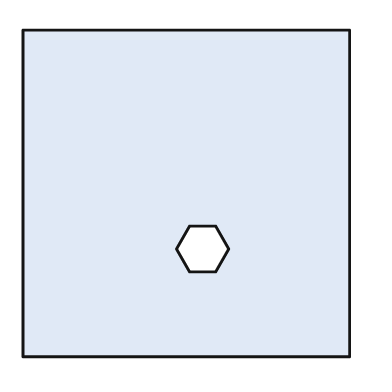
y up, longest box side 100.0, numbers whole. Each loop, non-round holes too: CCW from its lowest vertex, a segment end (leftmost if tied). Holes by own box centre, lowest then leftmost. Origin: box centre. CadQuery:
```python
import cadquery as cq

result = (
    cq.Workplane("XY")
    .moveTo(-50.0, -50.0)
    .lineTo(50.0, -50.0)
    .lineTo(50.0, 50.0)
    .lineTo(-50.0, 50.0)
    .close()
    .moveTo(1.0, -24.0)
    .lineTo(9.0, -24.0)
    .lineTo(13.0, -17.0)
    .lineTo(9.0, -10.0)
    .lineTo(1.0, -10.0)
    .lineTo(-3.0, -17.0)
    .close()
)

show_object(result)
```